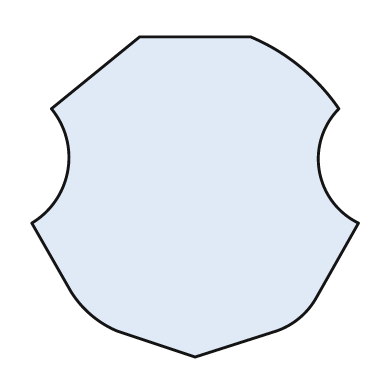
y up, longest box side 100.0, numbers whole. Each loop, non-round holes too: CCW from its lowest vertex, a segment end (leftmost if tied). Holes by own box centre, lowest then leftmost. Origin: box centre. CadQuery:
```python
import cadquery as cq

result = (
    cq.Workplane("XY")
    .moveTo(0.0, -49.0)
    .lineTo(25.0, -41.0)
    .threePointArc((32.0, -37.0), (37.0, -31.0))
    .lineTo(50.0, -8.0)
    .threePointArc((38.0, 8.0), (44.0, 27.0))
    .threePointArc((32.0, 40.0), (17.0, 49.0))
    .lineTo(-17.0, 49.0)
    .lineTo(-44.0, 27.0)
    .threePointArc((-39.0, 8.0), (-50.0, -8.0))
    .lineTo(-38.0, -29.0)
    .threePointArc((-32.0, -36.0), (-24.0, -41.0))
    .close()
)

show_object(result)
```